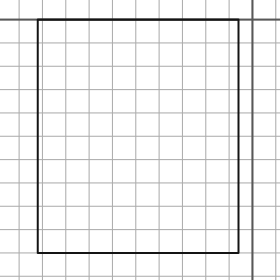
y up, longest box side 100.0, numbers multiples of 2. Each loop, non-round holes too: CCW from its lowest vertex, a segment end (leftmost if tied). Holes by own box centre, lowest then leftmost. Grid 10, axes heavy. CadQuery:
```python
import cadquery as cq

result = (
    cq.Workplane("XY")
    .moveTo(-92.0, -100.0)
    .lineTo(-6.0, -100.0)
    .lineTo(-6.0, 0.0)
    .lineTo(-92.0, 0.0)
    .close()
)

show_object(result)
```